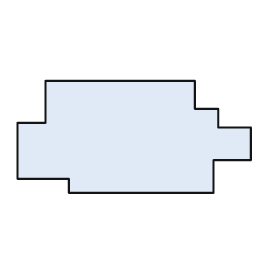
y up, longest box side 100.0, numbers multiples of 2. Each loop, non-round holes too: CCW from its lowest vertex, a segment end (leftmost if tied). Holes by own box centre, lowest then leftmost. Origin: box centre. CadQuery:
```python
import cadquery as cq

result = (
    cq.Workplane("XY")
    .moveTo(-28.0, -24.0)
    .lineTo(34.0, -24.0)
    .lineTo(34.0, -10.0)
    .lineTo(50.0, -10.0)
    .lineTo(50.0, 4.0)
    .lineTo(36.0, 4.0)
    .lineTo(36.0, 12.0)
    .lineTo(26.0, 12.0)
    .lineTo(26.0, 24.0)
    .lineTo(-38.0, 24.0)
    .lineTo(-38.0, 6.0)
    .lineTo(-50.0, 6.0)
    .lineTo(-50.0, -18.0)
    .lineTo(-28.0, -18.0)
    .close()
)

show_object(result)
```